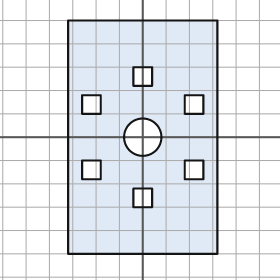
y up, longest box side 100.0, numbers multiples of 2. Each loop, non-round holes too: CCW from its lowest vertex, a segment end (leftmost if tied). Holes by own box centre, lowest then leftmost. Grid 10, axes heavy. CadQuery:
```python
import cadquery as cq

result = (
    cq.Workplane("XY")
    .moveTo(-32.0, -50.0)
    .lineTo(32.0, -50.0)
    .lineTo(32.0, 50.0)
    .lineTo(-32.0, 50.0)
    .close()
    .moveTo(-4.0, -30.0)
    .lineTo(4.0, -30.0)
    .lineTo(4.0, -22.0)
    .lineTo(-4.0, -22.0)
    .close()
    .moveTo(-26.0, -18.0)
    .lineTo(-18.0, -18.0)
    .lineTo(-18.0, -10.0)
    .lineTo(-26.0, -10.0)
    .close()
    .moveTo(18.0, -18.0)
    .lineTo(26.0, -18.0)
    .lineTo(26.0, -10.0)
    .lineTo(18.0, -10.0)
    .close()
    .moveTo(0.0, 0.0)
    .circle(8.0)
    .moveTo(-26.0, 10.0)
    .lineTo(-18.0, 10.0)
    .lineTo(-18.0, 18.0)
    .lineTo(-26.0, 18.0)
    .close()
    .moveTo(18.0, 10.0)
    .lineTo(26.0, 10.0)
    .lineTo(26.0, 18.0)
    .lineTo(18.0, 18.0)
    .close()
    .moveTo(-4.0, 22.0)
    .lineTo(4.0, 22.0)
    .lineTo(4.0, 30.0)
    .lineTo(-4.0, 30.0)
    .close()
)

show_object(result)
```